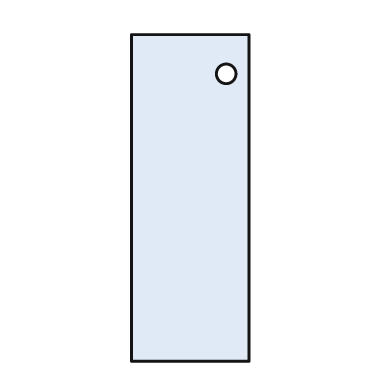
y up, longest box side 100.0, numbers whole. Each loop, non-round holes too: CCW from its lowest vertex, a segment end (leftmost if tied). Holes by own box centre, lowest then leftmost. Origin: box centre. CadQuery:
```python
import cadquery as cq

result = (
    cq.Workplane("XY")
    .moveTo(-18.0, -50.0)
    .lineTo(18.0, -50.0)
    .lineTo(18.0, 50.0)
    .lineTo(-18.0, 50.0)
    .close()
    .moveTo(11.0, 38.0)
    .circle(3.0)
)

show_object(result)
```